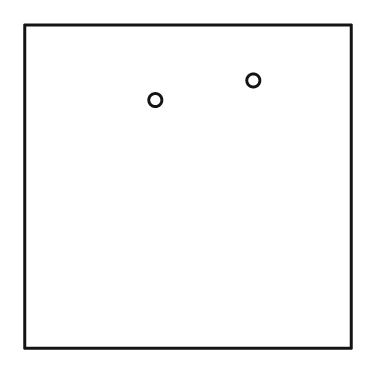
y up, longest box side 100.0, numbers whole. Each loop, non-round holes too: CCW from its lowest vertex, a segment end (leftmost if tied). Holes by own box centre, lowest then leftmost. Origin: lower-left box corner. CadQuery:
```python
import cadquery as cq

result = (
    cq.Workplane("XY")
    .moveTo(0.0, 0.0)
    .lineTo(100.0, 0.0)
    .lineTo(100.0, 99.0)
    .lineTo(0.0, 99.0)
    .close()
    .moveTo(40.0, 76.0)
    .circle(2.0)
    .moveTo(70.0, 82.0)
    .circle(2.0)
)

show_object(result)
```